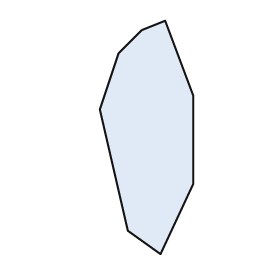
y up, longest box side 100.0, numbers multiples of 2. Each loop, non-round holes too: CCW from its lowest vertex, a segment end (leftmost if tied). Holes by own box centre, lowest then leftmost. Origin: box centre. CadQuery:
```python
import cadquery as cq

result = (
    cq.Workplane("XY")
    .moveTo(6.0, -50.0)
    .lineTo(20.0, -20.0)
    .lineTo(20.0, 18.0)
    .lineTo(8.0, 50.0)
    .lineTo(-2.0, 46.0)
    .lineTo(-12.0, 36.0)
    .lineTo(-20.0, 12.0)
    .lineTo(-8.0, -40.0)
    .close()
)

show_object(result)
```